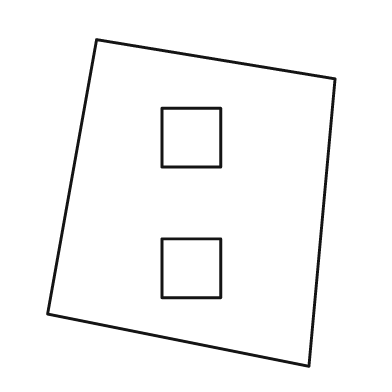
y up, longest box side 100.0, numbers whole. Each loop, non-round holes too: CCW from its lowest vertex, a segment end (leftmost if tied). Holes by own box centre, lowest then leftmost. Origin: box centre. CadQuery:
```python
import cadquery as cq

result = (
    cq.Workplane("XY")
    .moveTo(36.0, -50.0)
    .lineTo(44.0, 38.0)
    .lineTo(-29.0, 50.0)
    .lineTo(-44.0, -34.0)
    .close()
    .moveTo(-9.0, -29.0)
    .lineTo(9.0, -29.0)
    .lineTo(9.0, -11.0)
    .lineTo(-9.0, -11.0)
    .close()
    .moveTo(-9.0, 11.0)
    .lineTo(9.0, 11.0)
    .lineTo(9.0, 29.0)
    .lineTo(-9.0, 29.0)
    .close()
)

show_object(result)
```